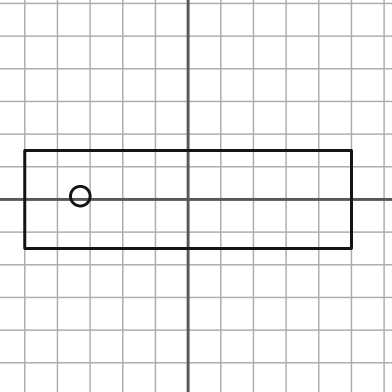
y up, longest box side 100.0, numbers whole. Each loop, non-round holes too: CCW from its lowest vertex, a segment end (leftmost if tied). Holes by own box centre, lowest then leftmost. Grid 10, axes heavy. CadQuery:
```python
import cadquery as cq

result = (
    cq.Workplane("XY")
    .moveTo(-50.0, -15.0)
    .lineTo(50.0, -15.0)
    .lineTo(50.0, 15.0)
    .lineTo(-50.0, 15.0)
    .close()
    .moveTo(-33.0, 1.0)
    .circle(3.0)
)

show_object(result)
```